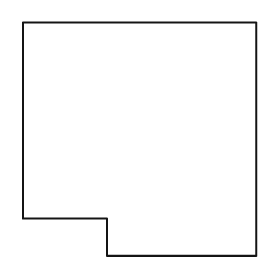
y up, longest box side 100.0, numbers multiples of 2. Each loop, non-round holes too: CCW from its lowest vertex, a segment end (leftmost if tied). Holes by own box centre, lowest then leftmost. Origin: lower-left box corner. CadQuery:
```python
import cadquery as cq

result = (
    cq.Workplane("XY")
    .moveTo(36.0, 0.0)
    .lineTo(100.0, 0.0)
    .lineTo(100.0, 100.0)
    .lineTo(0.0, 100.0)
    .lineTo(0.0, 16.0)
    .lineTo(36.0, 16.0)
    .close()
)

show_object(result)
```